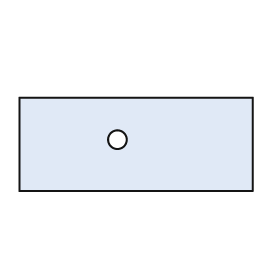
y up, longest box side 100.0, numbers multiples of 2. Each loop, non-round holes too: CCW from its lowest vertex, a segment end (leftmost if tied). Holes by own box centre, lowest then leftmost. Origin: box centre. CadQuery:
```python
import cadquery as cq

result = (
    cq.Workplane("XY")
    .moveTo(-50.0, -20.0)
    .lineTo(50.0, -20.0)
    .lineTo(50.0, 20.0)
    .lineTo(-50.0, 20.0)
    .close()
    .moveTo(-8.0, 2.0)
    .circle(4.0)
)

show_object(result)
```